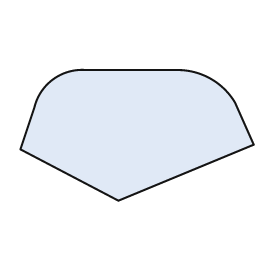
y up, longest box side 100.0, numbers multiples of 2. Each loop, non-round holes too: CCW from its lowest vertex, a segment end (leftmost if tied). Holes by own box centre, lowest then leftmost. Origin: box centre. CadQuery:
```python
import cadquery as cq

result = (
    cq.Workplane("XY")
    .moveTo(-8.0, -28.0)
    .lineTo(50.0, -4.0)
    .lineTo(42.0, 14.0)
    .threePointArc((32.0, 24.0), (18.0, 28.0))
    .lineTo(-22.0, 28.0)
    .threePointArc((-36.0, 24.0), (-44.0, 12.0))
    .lineTo(-50.0, -6.0)
    .close()
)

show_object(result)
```